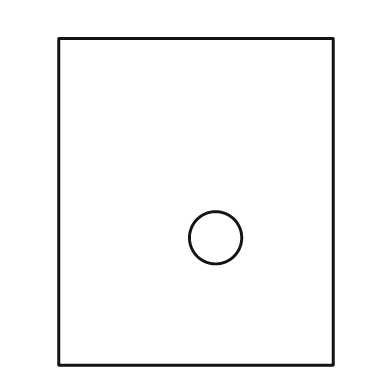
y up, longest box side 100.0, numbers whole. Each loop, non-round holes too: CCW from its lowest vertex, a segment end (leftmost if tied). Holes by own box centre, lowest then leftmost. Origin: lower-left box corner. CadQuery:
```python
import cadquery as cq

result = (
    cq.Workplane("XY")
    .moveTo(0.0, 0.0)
    .lineTo(84.0, 0.0)
    .lineTo(84.0, 100.0)
    .lineTo(0.0, 100.0)
    .close()
    .moveTo(48.0, 39.0)
    .circle(8.0)
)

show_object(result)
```